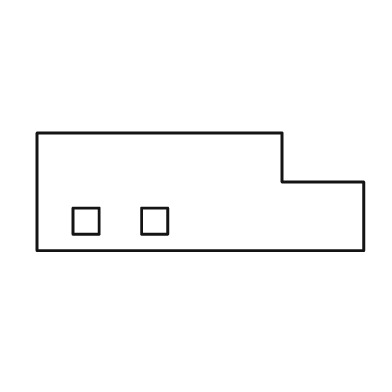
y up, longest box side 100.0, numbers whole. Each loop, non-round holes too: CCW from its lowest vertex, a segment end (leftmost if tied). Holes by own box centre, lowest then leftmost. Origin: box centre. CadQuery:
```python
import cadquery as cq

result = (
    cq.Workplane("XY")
    .moveTo(-50.0, -18.0)
    .lineTo(50.0, -18.0)
    .lineTo(50.0, 3.0)
    .lineTo(25.0, 3.0)
    .lineTo(25.0, 18.0)
    .lineTo(-50.0, 18.0)
    .close()
    .moveTo(-39.0, -13.0)
    .lineTo(-31.0, -13.0)
    .lineTo(-31.0, -5.0)
    .lineTo(-39.0, -5.0)
    .close()
    .moveTo(-18.0, -13.0)
    .lineTo(-10.0, -13.0)
    .lineTo(-10.0, -5.0)
    .lineTo(-18.0, -5.0)
    .close()
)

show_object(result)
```